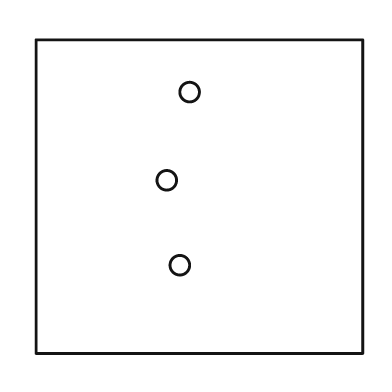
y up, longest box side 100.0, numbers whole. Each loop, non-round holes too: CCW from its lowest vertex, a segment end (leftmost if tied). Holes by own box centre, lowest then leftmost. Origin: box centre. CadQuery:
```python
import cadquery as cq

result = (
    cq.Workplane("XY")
    .moveTo(-50.0, -48.0)
    .lineTo(50.0, -48.0)
    .lineTo(50.0, 48.0)
    .lineTo(-50.0, 48.0)
    .close()
    .moveTo(-6.0, -21.0)
    .circle(3.0)
    .moveTo(-10.0, 5.0)
    .circle(3.0)
    .moveTo(-3.0, 32.0)
    .circle(3.0)
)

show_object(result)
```